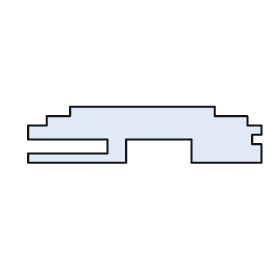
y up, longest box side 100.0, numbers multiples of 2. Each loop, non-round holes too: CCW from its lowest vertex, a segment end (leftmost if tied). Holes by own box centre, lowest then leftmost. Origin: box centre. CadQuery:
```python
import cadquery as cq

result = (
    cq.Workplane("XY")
    .moveTo(-50.0, -12.0)
    .lineTo(-8.0, -12.0)
    .lineTo(-8.0, -2.0)
    .lineTo(20.0, -2.0)
    .lineTo(20.0, -12.0)
    .lineTo(50.0, -12.0)
    .lineTo(50.0, -4.0)
    .lineTo(46.0, -4.0)
    .lineTo(46.0, 0.0)
    .lineTo(50.0, 0.0)
    .lineTo(50.0, 4.0)
    .lineTo(44.0, 4.0)
    .lineTo(44.0, 8.0)
    .lineTo(30.0, 8.0)
    .lineTo(30.0, 12.0)
    .lineTo(-32.0, 12.0)
    .lineTo(-32.0, 8.0)
    .lineTo(-42.0, 8.0)
    .lineTo(-42.0, 4.0)
    .lineTo(-50.0, 4.0)
    .lineTo(-50.0, -2.0)
    .lineTo(-16.0, -2.0)
    .lineTo(-16.0, -8.0)
    .lineTo(-50.0, -8.0)
    .close()
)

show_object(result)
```